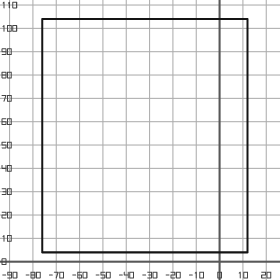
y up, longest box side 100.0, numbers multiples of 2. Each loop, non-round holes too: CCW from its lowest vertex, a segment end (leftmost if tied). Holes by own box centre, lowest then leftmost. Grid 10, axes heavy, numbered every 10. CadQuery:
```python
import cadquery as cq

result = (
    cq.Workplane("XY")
    .moveTo(-76.0, 4.0)
    .lineTo(12.0, 4.0)
    .lineTo(12.0, 104.0)
    .lineTo(-76.0, 104.0)
    .close()
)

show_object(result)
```